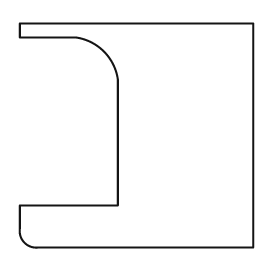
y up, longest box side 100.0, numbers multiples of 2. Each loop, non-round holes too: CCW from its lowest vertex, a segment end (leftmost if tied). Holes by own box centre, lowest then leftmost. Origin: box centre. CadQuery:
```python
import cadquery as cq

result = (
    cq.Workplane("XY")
    .moveTo(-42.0, -48.0)
    .lineTo(50.0, -48.0)
    .lineTo(50.0, 48.0)
    .lineTo(-50.0, 48.0)
    .lineTo(-50.0, 42.0)
    .lineTo(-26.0, 42.0)
    .threePointArc((-14.0, 36.0), (-8.0, 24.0))
    .lineTo(-8.0, -30.0)
    .lineTo(-50.0, -30.0)
    .lineTo(-50.0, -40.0)
    .threePointArc((-48.0, -46.0), (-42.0, -48.0))
    .close()
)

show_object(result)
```